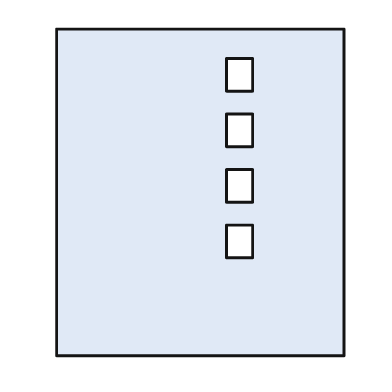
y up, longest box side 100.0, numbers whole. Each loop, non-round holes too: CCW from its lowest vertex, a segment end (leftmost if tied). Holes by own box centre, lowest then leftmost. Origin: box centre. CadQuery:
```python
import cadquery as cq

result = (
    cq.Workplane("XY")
    .moveTo(-44.0, -50.0)
    .lineTo(44.0, -50.0)
    .lineTo(44.0, 50.0)
    .lineTo(-44.0, 50.0)
    .close()
    .moveTo(8.0, -20.0)
    .lineTo(16.0, -20.0)
    .lineTo(16.0, -10.0)
    .lineTo(8.0, -10.0)
    .close()
    .moveTo(8.0, -3.0)
    .lineTo(16.0, -3.0)
    .lineTo(16.0, 7.0)
    .lineTo(8.0, 7.0)
    .close()
    .moveTo(8.0, 14.0)
    .lineTo(16.0, 14.0)
    .lineTo(16.0, 24.0)
    .lineTo(8.0, 24.0)
    .close()
    .moveTo(8.0, 31.0)
    .lineTo(16.0, 31.0)
    .lineTo(16.0, 41.0)
    .lineTo(8.0, 41.0)
    .close()
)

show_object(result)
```